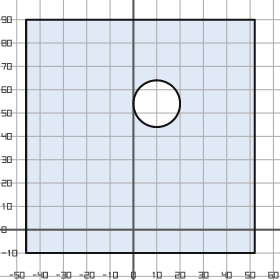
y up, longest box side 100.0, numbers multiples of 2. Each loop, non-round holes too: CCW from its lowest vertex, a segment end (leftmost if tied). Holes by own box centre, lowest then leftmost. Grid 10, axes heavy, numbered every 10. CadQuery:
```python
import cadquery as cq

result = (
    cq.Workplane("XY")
    .moveTo(-46.0, -10.0)
    .lineTo(52.0, -10.0)
    .lineTo(52.0, 90.0)
    .lineTo(-46.0, 90.0)
    .close()
    .moveTo(10.0, 54.0)
    .circle(10.0)
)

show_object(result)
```